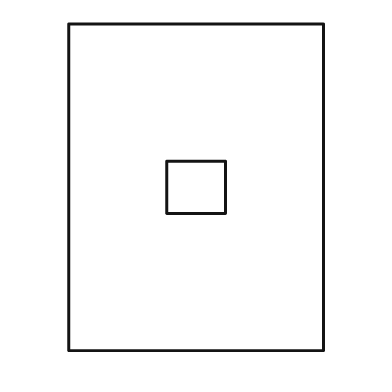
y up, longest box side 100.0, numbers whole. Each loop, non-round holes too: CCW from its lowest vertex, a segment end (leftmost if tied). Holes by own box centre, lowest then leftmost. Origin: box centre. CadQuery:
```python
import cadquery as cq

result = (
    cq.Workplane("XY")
    .moveTo(-39.0, -50.0)
    .lineTo(39.0, -50.0)
    .lineTo(39.0, 50.0)
    .lineTo(-39.0, 50.0)
    .close()
    .moveTo(-9.0, -8.0)
    .lineTo(9.0, -8.0)
    .lineTo(9.0, 8.0)
    .lineTo(-9.0, 8.0)
    .close()
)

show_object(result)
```